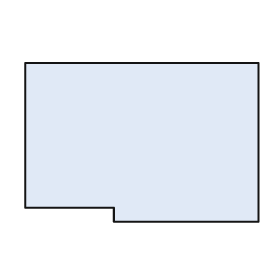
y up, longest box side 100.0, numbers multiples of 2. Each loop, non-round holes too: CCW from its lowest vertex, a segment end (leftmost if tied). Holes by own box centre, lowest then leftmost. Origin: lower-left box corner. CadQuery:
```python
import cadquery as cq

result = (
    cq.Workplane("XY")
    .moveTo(38.0, 0.0)
    .lineTo(100.0, 0.0)
    .lineTo(100.0, 68.0)
    .lineTo(0.0, 68.0)
    .lineTo(0.0, 6.0)
    .lineTo(38.0, 6.0)
    .close()
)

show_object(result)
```